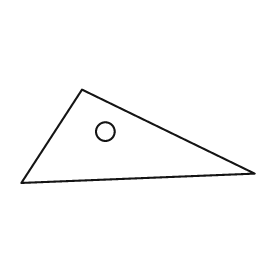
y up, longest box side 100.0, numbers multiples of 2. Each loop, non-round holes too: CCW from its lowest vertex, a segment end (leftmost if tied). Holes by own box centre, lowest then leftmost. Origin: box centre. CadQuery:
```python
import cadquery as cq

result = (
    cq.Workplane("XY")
    .moveTo(-50.0, -20.0)
    .lineTo(50.0, -16.0)
    .lineTo(-24.0, 20.0)
    .close()
    .moveTo(-14.0, 2.0)
    .circle(4.0)
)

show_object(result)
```